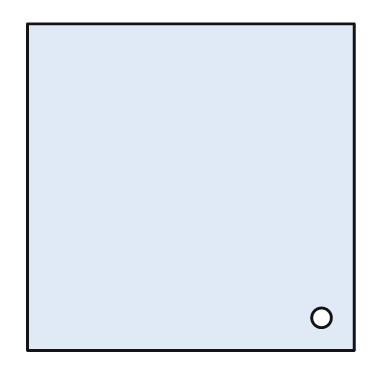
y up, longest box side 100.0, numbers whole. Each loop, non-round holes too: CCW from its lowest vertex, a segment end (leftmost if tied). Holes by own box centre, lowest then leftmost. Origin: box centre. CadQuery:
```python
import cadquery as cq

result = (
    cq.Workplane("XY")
    .moveTo(-50.0, -50.0)
    .lineTo(50.0, -50.0)
    .lineTo(50.0, 50.0)
    .lineTo(-50.0, 50.0)
    .close()
    .moveTo(40.0, -40.0)
    .circle(3.0)
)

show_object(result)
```